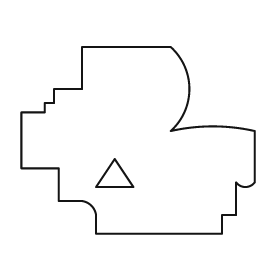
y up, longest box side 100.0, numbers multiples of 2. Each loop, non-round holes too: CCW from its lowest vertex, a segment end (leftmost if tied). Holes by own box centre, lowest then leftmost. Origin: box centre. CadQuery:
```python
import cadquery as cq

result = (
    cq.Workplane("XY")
    .moveTo(-18.0, -40.0)
    .lineTo(36.0, -40.0)
    .lineTo(36.0, -32.0)
    .lineTo(42.0, -32.0)
    .lineTo(42.0, -18.0)
    .threePointArc((46.0, -20.0), (50.0, -18.0))
    .lineTo(50.0, 4.0)
    .threePointArc((32.0, 6.0), (14.0, 4.0))
    .threePointArc((22.0, 22.0), (14.0, 40.0))
    .lineTo(-24.0, 40.0)
    .lineTo(-24.0, 22.0)
    .lineTo(-36.0, 22.0)
    .lineTo(-36.0, 16.0)
    .lineTo(-40.0, 16.0)
    .lineTo(-40.0, 12.0)
    .lineTo(-50.0, 12.0)
    .lineTo(-50.0, -12.0)
    .lineTo(-34.0, -12.0)
    .lineTo(-34.0, -26.0)
    .lineTo(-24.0, -26.0)
    .threePointArc((-20.0, -28.0), (-18.0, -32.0))
    .close()
    .moveTo(-18.0, -20.0)
    .lineTo(-2.0, -20.0)
    .lineTo(-10.0, -8.0)
    .close()
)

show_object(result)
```